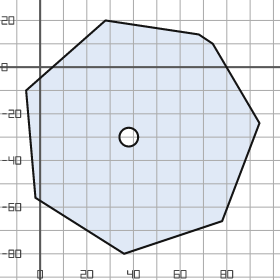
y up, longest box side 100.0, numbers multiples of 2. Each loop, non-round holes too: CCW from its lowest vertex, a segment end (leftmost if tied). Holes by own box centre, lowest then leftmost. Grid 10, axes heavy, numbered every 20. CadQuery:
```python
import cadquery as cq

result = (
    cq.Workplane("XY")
    .moveTo(36.0, -80.0)
    .lineTo(78.0, -66.0)
    .lineTo(94.0, -24.0)
    .lineTo(74.0, 10.0)
    .lineTo(68.0, 14.0)
    .lineTo(28.0, 20.0)
    .lineTo(-6.0, -10.0)
    .lineTo(-2.0, -56.0)
    .close()
    .moveTo(38.0, -30.0)
    .circle(4.0)
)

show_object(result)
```